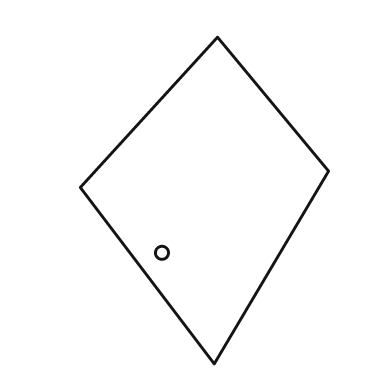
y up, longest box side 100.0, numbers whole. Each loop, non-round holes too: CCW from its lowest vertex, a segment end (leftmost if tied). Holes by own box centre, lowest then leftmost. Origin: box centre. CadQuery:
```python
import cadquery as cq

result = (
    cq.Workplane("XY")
    .moveTo(3.0, -50.0)
    .lineTo(38.0, 9.0)
    .lineTo(4.0, 50.0)
    .lineTo(-38.0, 4.0)
    .close()
    .moveTo(-13.0, -16.0)
    .circle(2.0)
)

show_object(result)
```